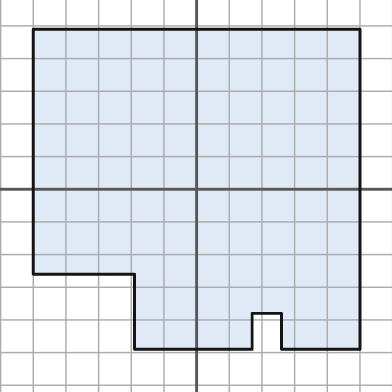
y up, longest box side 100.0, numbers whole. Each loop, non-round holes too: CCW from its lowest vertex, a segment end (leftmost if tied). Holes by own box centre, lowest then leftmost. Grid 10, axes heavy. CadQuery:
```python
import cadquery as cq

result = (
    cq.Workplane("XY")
    .moveTo(-19.0, -49.0)
    .lineTo(17.0, -49.0)
    .lineTo(17.0, -38.0)
    .lineTo(26.0, -38.0)
    .lineTo(26.0, -49.0)
    .lineTo(50.0, -49.0)
    .lineTo(50.0, 49.0)
    .lineTo(-50.0, 49.0)
    .lineTo(-50.0, -26.0)
    .lineTo(-19.0, -26.0)
    .close()
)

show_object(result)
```